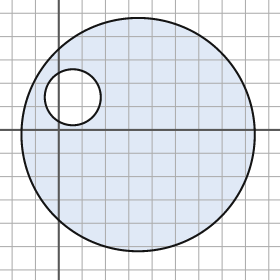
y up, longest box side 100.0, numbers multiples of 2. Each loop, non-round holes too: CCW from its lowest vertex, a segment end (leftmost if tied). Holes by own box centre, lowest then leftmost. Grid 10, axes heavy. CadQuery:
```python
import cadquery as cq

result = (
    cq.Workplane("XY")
    .moveTo(34.0, -2.0)
    .circle(50.0)
    .moveTo(6.0, 14.0)
    .circle(12.0)
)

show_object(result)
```